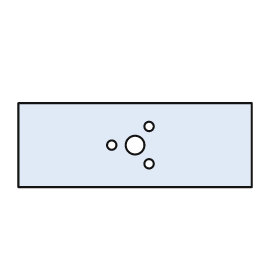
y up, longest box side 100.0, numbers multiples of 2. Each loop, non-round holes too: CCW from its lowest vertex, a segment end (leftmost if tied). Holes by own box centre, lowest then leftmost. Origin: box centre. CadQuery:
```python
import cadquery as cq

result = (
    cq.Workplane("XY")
    .moveTo(-50.0, -18.0)
    .lineTo(50.0, -18.0)
    .lineTo(50.0, 18.0)
    .lineTo(-50.0, 18.0)
    .close()
    .moveTo(6.0, -8.0)
    .circle(2.0)
    .moveTo(-10.0, 0.0)
    .circle(2.0)
    .moveTo(0.0, 0.0)
    .circle(4.0)
    .moveTo(6.0, 8.0)
    .circle(2.0)
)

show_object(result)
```